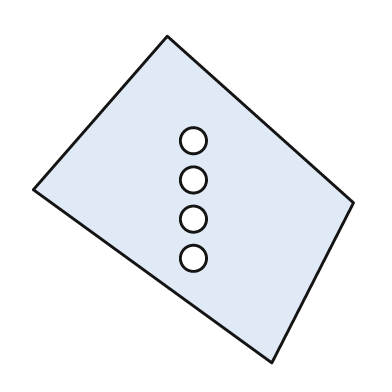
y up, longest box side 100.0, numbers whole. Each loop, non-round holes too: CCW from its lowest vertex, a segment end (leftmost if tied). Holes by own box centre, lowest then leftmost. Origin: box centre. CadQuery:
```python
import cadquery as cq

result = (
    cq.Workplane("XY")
    .moveTo(24.0, -50.0)
    .lineTo(49.0, -1.0)
    .lineTo(-8.0, 50.0)
    .lineTo(-49.0, 3.0)
    .close()
    .moveTo(0.0, -18.0)
    .circle(4.0)
    .moveTo(0.0, -6.0)
    .circle(4.0)
    .moveTo(0.0, 6.0)
    .circle(4.0)
    .moveTo(0.0, 18.0)
    .circle(4.0)
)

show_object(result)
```